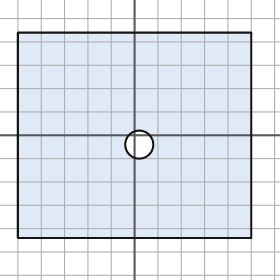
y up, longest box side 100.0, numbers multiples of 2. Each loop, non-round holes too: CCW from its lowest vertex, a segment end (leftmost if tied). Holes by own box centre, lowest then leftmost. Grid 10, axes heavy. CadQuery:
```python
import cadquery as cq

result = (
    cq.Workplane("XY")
    .moveTo(-50.0, -44.0)
    .lineTo(50.0, -44.0)
    .lineTo(50.0, 44.0)
    .lineTo(-50.0, 44.0)
    .close()
    .moveTo(2.0, -4.0)
    .circle(6.0)
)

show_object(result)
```